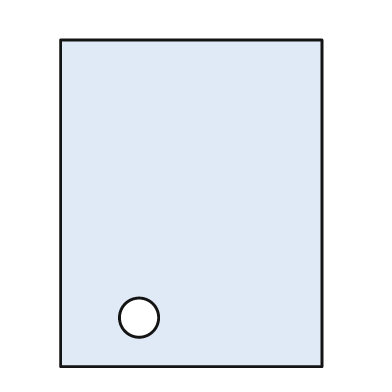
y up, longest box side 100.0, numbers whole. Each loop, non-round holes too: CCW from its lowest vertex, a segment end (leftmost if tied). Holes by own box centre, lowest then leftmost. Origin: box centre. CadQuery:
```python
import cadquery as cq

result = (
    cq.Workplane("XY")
    .moveTo(-40.0, -50.0)
    .lineTo(40.0, -50.0)
    .lineTo(40.0, 50.0)
    .lineTo(-40.0, 50.0)
    .close()
    .moveTo(-16.0, -35.0)
    .circle(6.0)
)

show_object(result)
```